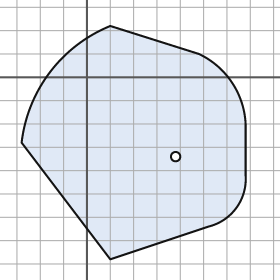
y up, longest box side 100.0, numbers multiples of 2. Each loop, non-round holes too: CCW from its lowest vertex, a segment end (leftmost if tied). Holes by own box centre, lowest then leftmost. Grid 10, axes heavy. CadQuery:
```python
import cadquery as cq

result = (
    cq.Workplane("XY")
    .moveTo(10.0, -78.0)
    .lineTo(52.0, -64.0)
    .threePointArc((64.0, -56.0), (68.0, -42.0))
    .lineTo(68.0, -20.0)
    .threePointArc((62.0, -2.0), (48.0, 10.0))
    .lineTo(10.0, 22.0)
    .threePointArc((-16.0, 2.0), (-28.0, -28.0))
    .close()
    .moveTo(38.0, -34.0)
    .circle(2.0)
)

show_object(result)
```